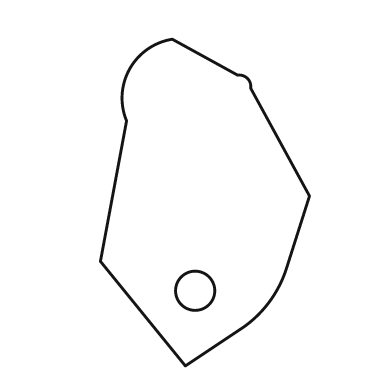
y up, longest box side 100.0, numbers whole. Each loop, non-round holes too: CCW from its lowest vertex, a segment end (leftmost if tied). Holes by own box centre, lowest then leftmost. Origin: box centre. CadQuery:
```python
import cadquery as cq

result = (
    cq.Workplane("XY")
    .moveTo(-6.0, -50.0)
    .lineTo(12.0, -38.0)
    .threePointArc((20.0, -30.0), (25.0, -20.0))
    .lineTo(32.0, 2.0)
    .lineTo(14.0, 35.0)
    .threePointArc((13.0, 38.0), (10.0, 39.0))
    .lineTo(-10.0, 50.0)
    .threePointArc((-23.0, 41.0), (-24.0, 25.0))
    .lineTo(-32.0, -18.0)
    .close()
    .moveTo(-3.0, -27.0)
    .circle(6.0)
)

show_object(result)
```